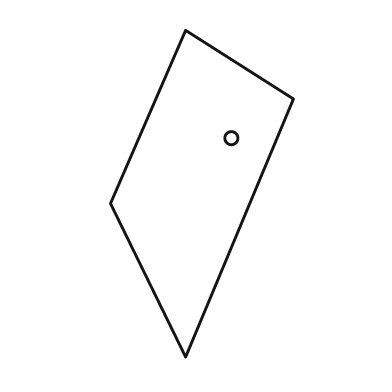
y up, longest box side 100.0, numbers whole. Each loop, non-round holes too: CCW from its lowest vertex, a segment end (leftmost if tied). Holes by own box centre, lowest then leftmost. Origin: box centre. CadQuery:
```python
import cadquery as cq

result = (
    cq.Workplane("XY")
    .moveTo(-5.0, -50.0)
    .lineTo(28.0, 29.0)
    .lineTo(-5.0, 50.0)
    .lineTo(-28.0, -3.0)
    .close()
    .moveTo(9.0, 17.0)
    .circle(2.0)
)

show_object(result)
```